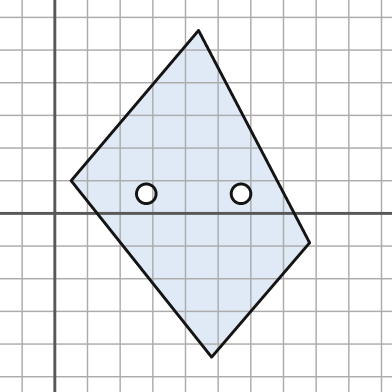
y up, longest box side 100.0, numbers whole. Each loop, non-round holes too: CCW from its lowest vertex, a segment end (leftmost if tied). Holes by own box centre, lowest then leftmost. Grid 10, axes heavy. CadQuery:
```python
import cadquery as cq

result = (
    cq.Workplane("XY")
    .moveTo(48.0, -44.0)
    .lineTo(78.0, -9.0)
    .lineTo(44.0, 56.0)
    .lineTo(5.0, 10.0)
    .close()
    .moveTo(28.0, 6.0)
    .circle(3.0)
    .moveTo(57.0, 6.0)
    .circle(3.0)
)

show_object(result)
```